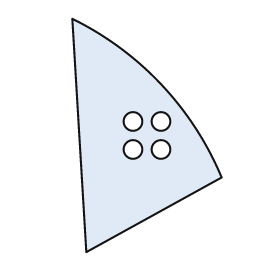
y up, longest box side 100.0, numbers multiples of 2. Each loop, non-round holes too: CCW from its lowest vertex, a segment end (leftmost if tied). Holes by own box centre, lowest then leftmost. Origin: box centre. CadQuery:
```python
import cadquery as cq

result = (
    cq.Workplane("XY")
    .moveTo(-26.0, -50.0)
    .lineTo(32.0, -18.0)
    .threePointArc((6.0, 22.0), (-32.0, 50.0))
    .close()
    .moveTo(-6.0, -6.0)
    .circle(4.0)
    .moveTo(6.0, -6.0)
    .circle(4.0)
    .moveTo(-6.0, 6.0)
    .circle(4.0)
    .moveTo(6.0, 6.0)
    .circle(4.0)
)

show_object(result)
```